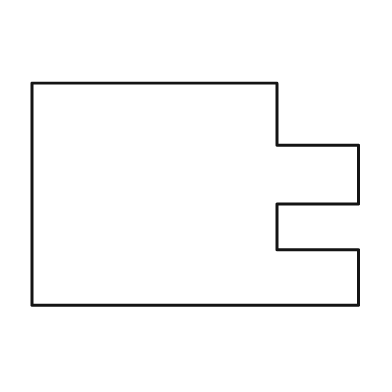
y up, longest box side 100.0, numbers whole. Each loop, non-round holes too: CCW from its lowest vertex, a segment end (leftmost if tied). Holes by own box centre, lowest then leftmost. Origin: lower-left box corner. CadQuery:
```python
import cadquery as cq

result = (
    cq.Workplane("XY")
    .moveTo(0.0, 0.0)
    .lineTo(100.0, 0.0)
    .lineTo(100.0, 17.0)
    .lineTo(75.0, 17.0)
    .lineTo(75.0, 31.0)
    .lineTo(100.0, 31.0)
    .lineTo(100.0, 49.0)
    .lineTo(75.0, 49.0)
    .lineTo(75.0, 68.0)
    .lineTo(0.0, 68.0)
    .close()
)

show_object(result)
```